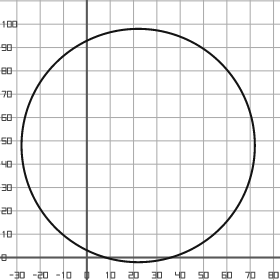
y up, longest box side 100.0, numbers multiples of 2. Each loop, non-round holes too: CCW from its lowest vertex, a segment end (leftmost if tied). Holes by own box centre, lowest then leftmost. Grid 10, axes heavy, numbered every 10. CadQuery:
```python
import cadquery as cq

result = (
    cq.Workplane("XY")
    .moveTo(22.0, 48.0)
    .circle(50.0)
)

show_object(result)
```